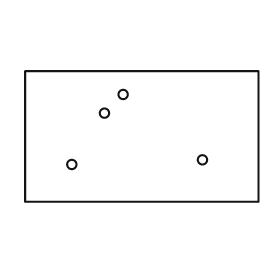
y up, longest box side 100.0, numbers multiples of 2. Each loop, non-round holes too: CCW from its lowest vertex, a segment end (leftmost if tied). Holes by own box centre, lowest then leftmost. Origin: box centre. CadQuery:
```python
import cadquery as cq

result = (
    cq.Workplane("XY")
    .moveTo(-50.0, -28.0)
    .lineTo(50.0, -28.0)
    .lineTo(50.0, 28.0)
    .lineTo(-50.0, 28.0)
    .close()
    .moveTo(-30.0, -12.0)
    .circle(2.0)
    .moveTo(26.0, -10.0)
    .circle(2.0)
    .moveTo(-16.0, 10.0)
    .circle(2.0)
    .moveTo(-8.0, 18.0)
    .circle(2.0)
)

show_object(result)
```